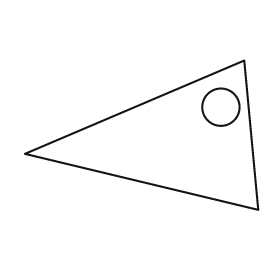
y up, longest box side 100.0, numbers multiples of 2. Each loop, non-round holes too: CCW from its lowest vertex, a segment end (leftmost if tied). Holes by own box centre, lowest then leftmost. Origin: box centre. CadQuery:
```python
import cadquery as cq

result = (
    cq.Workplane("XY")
    .moveTo(50.0, -32.0)
    .lineTo(44.0, 32.0)
    .lineTo(-50.0, -8.0)
    .close()
    .moveTo(34.0, 12.0)
    .circle(8.0)
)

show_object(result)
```